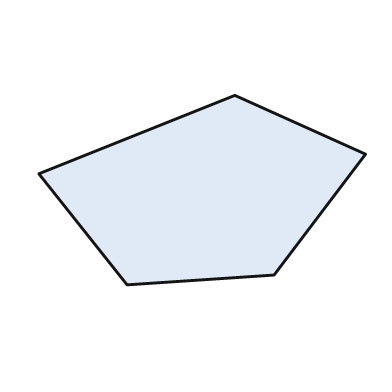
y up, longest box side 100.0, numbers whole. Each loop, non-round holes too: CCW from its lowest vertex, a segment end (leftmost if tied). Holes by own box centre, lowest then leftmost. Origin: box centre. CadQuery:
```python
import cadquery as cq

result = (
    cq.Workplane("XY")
    .moveTo(-23.0, -29.0)
    .lineTo(22.0, -26.0)
    .lineTo(50.0, 11.0)
    .lineTo(10.0, 29.0)
    .lineTo(-50.0, 5.0)
    .close()
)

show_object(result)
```